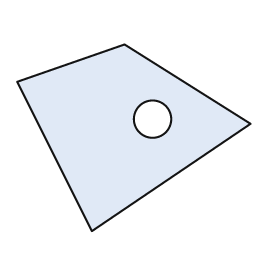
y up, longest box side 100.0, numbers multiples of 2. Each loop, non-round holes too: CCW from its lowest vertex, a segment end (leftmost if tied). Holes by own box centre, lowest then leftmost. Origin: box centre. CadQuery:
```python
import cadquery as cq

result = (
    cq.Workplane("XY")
    .moveTo(-18.0, -40.0)
    .lineTo(50.0, 6.0)
    .lineTo(-4.0, 40.0)
    .lineTo(-50.0, 24.0)
    .close()
    .moveTo(8.0, 8.0)
    .circle(8.0)
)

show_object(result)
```